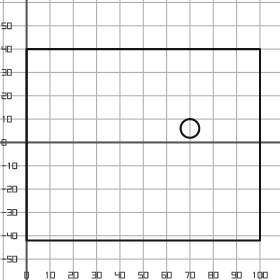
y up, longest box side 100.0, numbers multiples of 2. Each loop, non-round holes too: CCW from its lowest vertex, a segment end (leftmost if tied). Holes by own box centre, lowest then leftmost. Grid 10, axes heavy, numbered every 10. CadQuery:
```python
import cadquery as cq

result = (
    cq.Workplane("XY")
    .moveTo(0.0, -42.0)
    .lineTo(100.0, -42.0)
    .lineTo(100.0, 40.0)
    .lineTo(0.0, 40.0)
    .close()
    .moveTo(70.0, 6.0)
    .circle(4.0)
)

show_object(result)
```